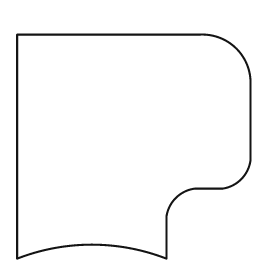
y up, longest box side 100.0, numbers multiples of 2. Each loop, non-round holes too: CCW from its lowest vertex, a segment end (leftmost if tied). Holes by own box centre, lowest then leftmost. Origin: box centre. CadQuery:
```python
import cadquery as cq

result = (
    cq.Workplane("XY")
    .moveTo(-50.0, -48.0)
    .threePointArc((-18.0, -42.0), (14.0, -48.0))
    .lineTo(14.0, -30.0)
    .threePointArc((18.0, -22.0), (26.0, -18.0))
    .lineTo(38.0, -18.0)
    .threePointArc((46.0, -14.0), (50.0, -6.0))
    .lineTo(50.0, 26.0)
    .threePointArc((44.0, 42.0), (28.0, 48.0))
    .lineTo(-50.0, 48.0)
    .close()
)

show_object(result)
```